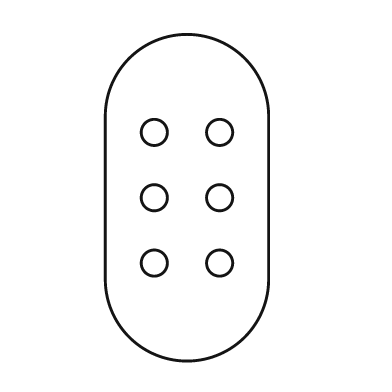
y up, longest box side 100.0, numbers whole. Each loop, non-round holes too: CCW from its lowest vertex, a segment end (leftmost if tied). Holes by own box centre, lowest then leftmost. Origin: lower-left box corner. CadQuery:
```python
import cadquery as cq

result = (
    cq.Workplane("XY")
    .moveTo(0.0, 25.0)
    .threePointArc((25.0, 0.0), (50.0, 25.0))
    .lineTo(50.0, 75.0)
    .threePointArc((25.0, 100.0), (0.0, 75.0))
    .close()
    .moveTo(15.0, 30.0)
    .circle(4.0)
    .moveTo(35.0, 30.0)
    .circle(4.0)
    .moveTo(15.0, 50.0)
    .circle(4.0)
    .moveTo(35.0, 50.0)
    .circle(4.0)
    .moveTo(15.0, 70.0)
    .circle(4.0)
    .moveTo(35.0, 70.0)
    .circle(4.0)
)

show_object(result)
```